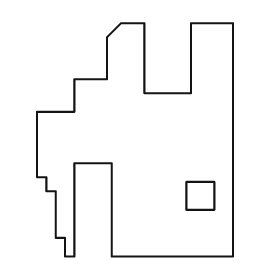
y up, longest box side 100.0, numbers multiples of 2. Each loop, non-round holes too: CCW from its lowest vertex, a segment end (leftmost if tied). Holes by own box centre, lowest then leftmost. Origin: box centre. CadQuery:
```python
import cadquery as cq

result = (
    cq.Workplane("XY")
    .moveTo(-30.0, -50.0)
    .lineTo(-26.0, -50.0)
    .lineTo(-26.0, -10.0)
    .lineTo(-10.0, -10.0)
    .lineTo(-10.0, -50.0)
    .lineTo(42.0, -50.0)
    .lineTo(42.0, 50.0)
    .lineTo(24.0, 50.0)
    .lineTo(24.0, 20.0)
    .lineTo(4.0, 20.0)
    .lineTo(4.0, 50.0)
    .lineTo(-6.0, 50.0)
    .lineTo(-12.0, 44.0)
    .lineTo(-12.0, 26.0)
    .lineTo(-26.0, 26.0)
    .lineTo(-26.0, 12.0)
    .lineTo(-42.0, 12.0)
    .lineTo(-42.0, -16.0)
    .lineTo(-38.0, -16.0)
    .lineTo(-38.0, -22.0)
    .lineTo(-34.0, -22.0)
    .lineTo(-34.0, -42.0)
    .lineTo(-30.0, -42.0)
    .close()
    .moveTo(22.0, -30.0)
    .lineTo(34.0, -30.0)
    .lineTo(34.0, -18.0)
    .lineTo(22.0, -18.0)
    .close()
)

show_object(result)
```